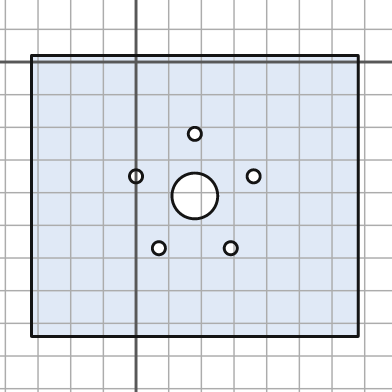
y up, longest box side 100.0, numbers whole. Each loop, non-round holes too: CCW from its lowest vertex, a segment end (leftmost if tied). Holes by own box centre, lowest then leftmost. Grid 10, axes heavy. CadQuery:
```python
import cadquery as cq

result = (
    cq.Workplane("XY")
    .moveTo(-32.0, -84.0)
    .lineTo(68.0, -84.0)
    .lineTo(68.0, 2.0)
    .lineTo(-32.0, 2.0)
    .close()
    .moveTo(7.0, -57.0)
    .circle(2.0)
    .moveTo(29.0, -57.0)
    .circle(2.0)
    .moveTo(18.0, -41.0)
    .circle(7.0)
    .moveTo(0.0, -35.0)
    .circle(2.0)
    .moveTo(36.0, -35.0)
    .circle(2.0)
    .moveTo(18.0, -22.0)
    .circle(2.0)
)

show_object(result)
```